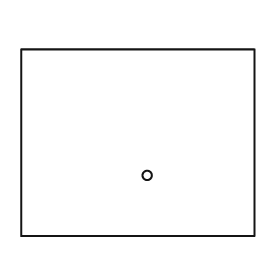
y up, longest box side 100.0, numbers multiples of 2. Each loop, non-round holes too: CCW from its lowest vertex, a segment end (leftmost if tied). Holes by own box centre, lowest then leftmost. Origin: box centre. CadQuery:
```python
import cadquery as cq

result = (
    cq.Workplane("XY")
    .moveTo(-50.0, -40.0)
    .lineTo(50.0, -40.0)
    .lineTo(50.0, 40.0)
    .lineTo(-50.0, 40.0)
    .close()
    .moveTo(4.0, -14.0)
    .circle(2.0)
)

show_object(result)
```